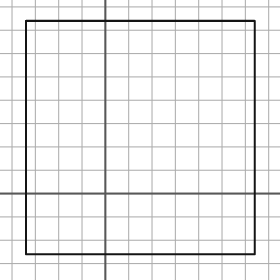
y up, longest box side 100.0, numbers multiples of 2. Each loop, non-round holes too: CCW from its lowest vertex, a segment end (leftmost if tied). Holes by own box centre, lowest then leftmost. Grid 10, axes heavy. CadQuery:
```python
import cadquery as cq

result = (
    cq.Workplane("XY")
    .moveTo(-34.0, -26.0)
    .lineTo(64.0, -26.0)
    .lineTo(64.0, 74.0)
    .lineTo(-34.0, 74.0)
    .close()
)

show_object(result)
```